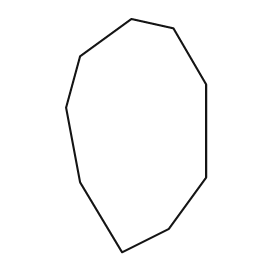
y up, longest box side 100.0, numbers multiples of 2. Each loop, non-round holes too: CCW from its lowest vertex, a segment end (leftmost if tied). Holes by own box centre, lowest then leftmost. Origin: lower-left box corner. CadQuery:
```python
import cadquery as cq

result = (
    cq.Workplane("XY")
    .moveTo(24.0, 0.0)
    .lineTo(44.0, 10.0)
    .lineTo(60.0, 32.0)
    .lineTo(60.0, 72.0)
    .lineTo(46.0, 96.0)
    .lineTo(28.0, 100.0)
    .lineTo(6.0, 84.0)
    .lineTo(0.0, 62.0)
    .lineTo(6.0, 30.0)
    .close()
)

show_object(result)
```